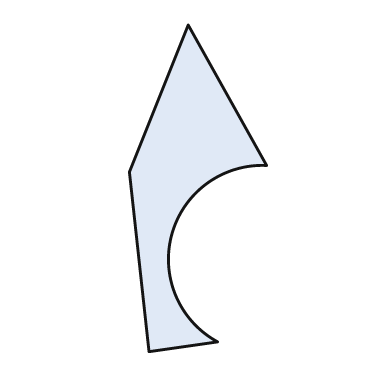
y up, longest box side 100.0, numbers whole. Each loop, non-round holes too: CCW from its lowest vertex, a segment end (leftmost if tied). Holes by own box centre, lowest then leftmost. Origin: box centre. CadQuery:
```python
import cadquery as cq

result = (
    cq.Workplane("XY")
    .moveTo(-15.0, -50.0)
    .lineTo(6.0, -47.0)
    .threePointArc((-8.0, -14.0), (21.0, 7.0))
    .lineTo(-3.0, 50.0)
    .lineTo(-21.0, 5.0)
    .close()
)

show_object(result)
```